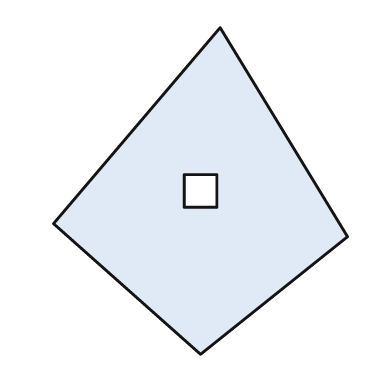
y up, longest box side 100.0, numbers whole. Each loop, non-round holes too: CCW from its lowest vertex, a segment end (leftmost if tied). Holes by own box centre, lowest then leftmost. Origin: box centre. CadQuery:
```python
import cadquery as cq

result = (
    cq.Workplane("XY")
    .moveTo(0.0, -50.0)
    .lineTo(45.0, -14.0)
    .lineTo(6.0, 50.0)
    .lineTo(-45.0, -10.0)
    .close()
    .moveTo(-5.0, -5.0)
    .lineTo(5.0, -5.0)
    .lineTo(5.0, 5.0)
    .lineTo(-5.0, 5.0)
    .close()
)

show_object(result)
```